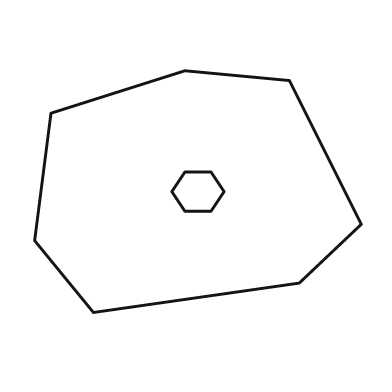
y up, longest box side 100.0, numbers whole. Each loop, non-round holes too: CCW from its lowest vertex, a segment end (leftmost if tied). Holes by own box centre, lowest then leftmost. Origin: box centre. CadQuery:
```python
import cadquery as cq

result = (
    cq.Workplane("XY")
    .moveTo(-32.0, -37.0)
    .lineTo(31.0, -28.0)
    .lineTo(50.0, -10.0)
    .lineTo(28.0, 34.0)
    .lineTo(-4.0, 37.0)
    .lineTo(-45.0, 24.0)
    .lineTo(-50.0, -15.0)
    .close()
    .moveTo(-4.0, -6.0)
    .lineTo(4.0, -6.0)
    .lineTo(8.0, 0.0)
    .lineTo(4.0, 6.0)
    .lineTo(-4.0, 6.0)
    .lineTo(-8.0, 0.0)
    .close()
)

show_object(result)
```